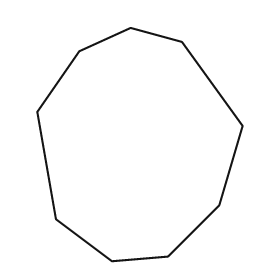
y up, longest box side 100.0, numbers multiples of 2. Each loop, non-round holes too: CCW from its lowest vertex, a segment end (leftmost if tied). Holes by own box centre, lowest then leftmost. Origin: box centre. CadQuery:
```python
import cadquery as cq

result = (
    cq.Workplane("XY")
    .moveTo(-12.0, -50.0)
    .lineTo(12.0, -48.0)
    .lineTo(34.0, -26.0)
    .lineTo(44.0, 8.0)
    .lineTo(18.0, 44.0)
    .lineTo(-4.0, 50.0)
    .lineTo(-26.0, 40.0)
    .lineTo(-44.0, 14.0)
    .lineTo(-36.0, -32.0)
    .close()
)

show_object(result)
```